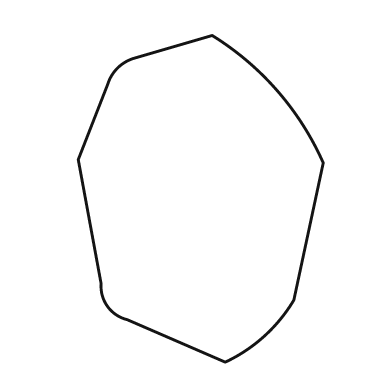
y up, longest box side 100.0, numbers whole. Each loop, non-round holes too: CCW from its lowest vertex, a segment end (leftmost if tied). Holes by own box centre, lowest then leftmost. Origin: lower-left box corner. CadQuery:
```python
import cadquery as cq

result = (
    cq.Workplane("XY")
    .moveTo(45.0, 0.0)
    .threePointArc((57.0, 8.0), (66.0, 19.0))
    .lineTo(75.0, 61.0)
    .threePointArc((61.0, 83.0), (41.0, 100.0))
    .lineTo(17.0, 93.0)
    .threePointArc((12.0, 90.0), (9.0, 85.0))
    .lineTo(0.0, 62.0)
    .lineTo(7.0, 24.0)
    .threePointArc((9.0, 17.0), (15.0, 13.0))
    .close()
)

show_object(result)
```